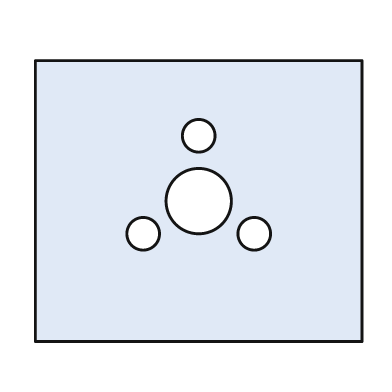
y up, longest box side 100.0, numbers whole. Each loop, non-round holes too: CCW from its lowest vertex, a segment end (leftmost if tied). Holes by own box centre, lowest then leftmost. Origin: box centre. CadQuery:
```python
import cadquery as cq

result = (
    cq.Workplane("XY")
    .moveTo(-50.0, -43.0)
    .lineTo(50.0, -43.0)
    .lineTo(50.0, 43.0)
    .lineTo(-50.0, 43.0)
    .close()
    .moveTo(-17.0, -10.0)
    .circle(5.0)
    .moveTo(17.0, -10.0)
    .circle(5.0)
    .moveTo(0.0, 0.0)
    .circle(10.0)
    .moveTo(0.0, 20.0)
    .circle(5.0)
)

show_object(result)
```